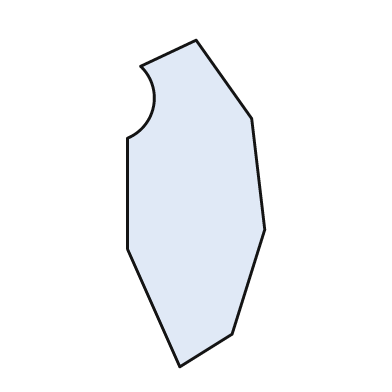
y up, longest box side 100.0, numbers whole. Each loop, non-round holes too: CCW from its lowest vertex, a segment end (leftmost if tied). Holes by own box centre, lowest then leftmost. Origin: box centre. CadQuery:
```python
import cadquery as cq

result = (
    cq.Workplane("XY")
    .moveTo(-5.0, -50.0)
    .lineTo(11.0, -40.0)
    .lineTo(21.0, -8.0)
    .lineTo(17.0, 26.0)
    .lineTo(0.0, 50.0)
    .lineTo(-17.0, 42.0)
    .threePointArc((-13.0, 30.0), (-21.0, 20.0))
    .lineTo(-21.0, -14.0)
    .close()
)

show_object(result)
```